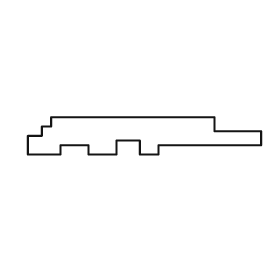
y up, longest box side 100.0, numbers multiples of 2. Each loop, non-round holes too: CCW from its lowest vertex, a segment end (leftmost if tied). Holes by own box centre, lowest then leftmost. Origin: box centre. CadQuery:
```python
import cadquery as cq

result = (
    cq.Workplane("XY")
    .moveTo(-50.0, -8.0)
    .lineTo(-36.0, -8.0)
    .lineTo(-36.0, -4.0)
    .lineTo(-24.0, -4.0)
    .lineTo(-24.0, -8.0)
    .lineTo(-12.0, -8.0)
    .lineTo(-12.0, -2.0)
    .lineTo(-2.0, -2.0)
    .lineTo(-2.0, -8.0)
    .lineTo(6.0, -8.0)
    .lineTo(6.0, -4.0)
    .lineTo(50.0, -4.0)
    .lineTo(50.0, 2.0)
    .lineTo(30.0, 2.0)
    .lineTo(30.0, 8.0)
    .lineTo(-40.0, 8.0)
    .lineTo(-40.0, 4.0)
    .lineTo(-44.0, 4.0)
    .lineTo(-44.0, 0.0)
    .lineTo(-50.0, 0.0)
    .close()
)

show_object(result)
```